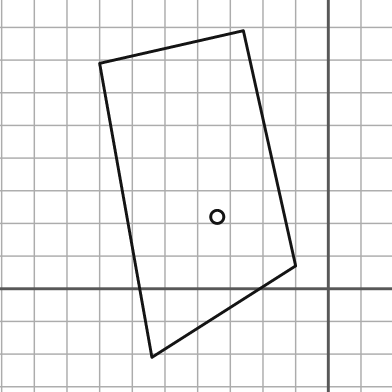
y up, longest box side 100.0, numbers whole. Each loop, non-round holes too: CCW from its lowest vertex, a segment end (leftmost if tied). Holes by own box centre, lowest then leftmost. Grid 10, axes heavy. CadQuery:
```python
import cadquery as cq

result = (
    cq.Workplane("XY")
    .moveTo(-54.0, -21.0)
    .lineTo(-10.0, 7.0)
    .lineTo(-26.0, 79.0)
    .lineTo(-70.0, 69.0)
    .close()
    .moveTo(-34.0, 22.0)
    .circle(2.0)
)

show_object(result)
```